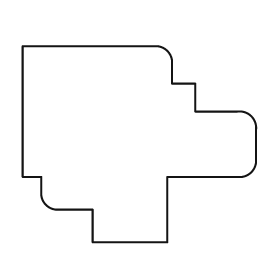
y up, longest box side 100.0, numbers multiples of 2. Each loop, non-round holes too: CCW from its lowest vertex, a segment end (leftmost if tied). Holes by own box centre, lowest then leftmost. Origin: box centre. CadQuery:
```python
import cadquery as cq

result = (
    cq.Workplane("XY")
    .moveTo(-20.0, -42.0)
    .lineTo(12.0, -42.0)
    .lineTo(12.0, -14.0)
    .lineTo(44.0, -14.0)
    .threePointArc((48.0, -12.0), (50.0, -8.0))
    .lineTo(50.0, 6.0)
    .threePointArc((48.0, 12.0), (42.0, 14.0))
    .lineTo(24.0, 14.0)
    .lineTo(24.0, 26.0)
    .lineTo(14.0, 26.0)
    .lineTo(14.0, 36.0)
    .threePointArc((12.0, 40.0), (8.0, 42.0))
    .lineTo(-50.0, 42.0)
    .lineTo(-50.0, -14.0)
    .lineTo(-42.0, -14.0)
    .lineTo(-42.0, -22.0)
    .threePointArc((-40.0, -26.0), (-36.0, -28.0))
    .lineTo(-20.0, -28.0)
    .close()
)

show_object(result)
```